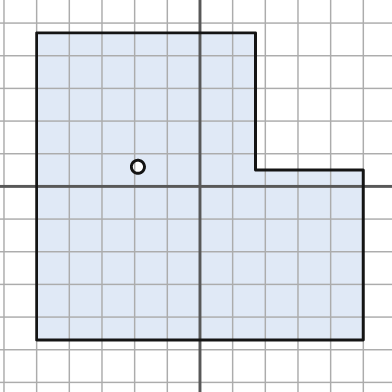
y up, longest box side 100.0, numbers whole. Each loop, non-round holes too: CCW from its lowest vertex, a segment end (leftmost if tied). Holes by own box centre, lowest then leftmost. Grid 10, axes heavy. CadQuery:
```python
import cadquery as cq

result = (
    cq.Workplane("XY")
    .moveTo(-50.0, -47.0)
    .lineTo(50.0, -47.0)
    .lineTo(50.0, 5.0)
    .lineTo(17.0, 5.0)
    .lineTo(17.0, 47.0)
    .lineTo(-50.0, 47.0)
    .close()
    .moveTo(-19.0, 6.0)
    .circle(2.0)
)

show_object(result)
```